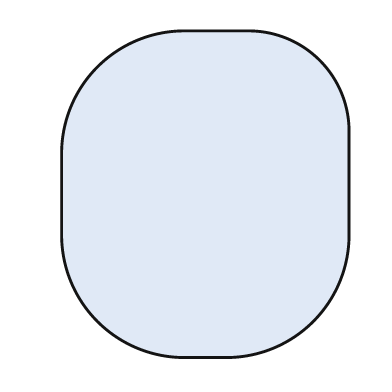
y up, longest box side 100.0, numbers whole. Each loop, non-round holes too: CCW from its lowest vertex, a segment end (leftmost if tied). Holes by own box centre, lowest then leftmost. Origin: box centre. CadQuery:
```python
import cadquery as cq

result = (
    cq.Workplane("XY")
    .moveTo(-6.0, -50.0)
    .lineTo(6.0, -50.0)
    .threePointArc((33.0, -39.0), (44.0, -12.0))
    .lineTo(44.0, 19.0)
    .threePointArc((35.0, 41.0), (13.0, 50.0))
    .lineTo(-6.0, 50.0)
    .threePointArc((-33.0, 39.0), (-44.0, 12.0))
    .lineTo(-44.0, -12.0)
    .threePointArc((-33.0, -39.0), (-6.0, -50.0))
    .close()
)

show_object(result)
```